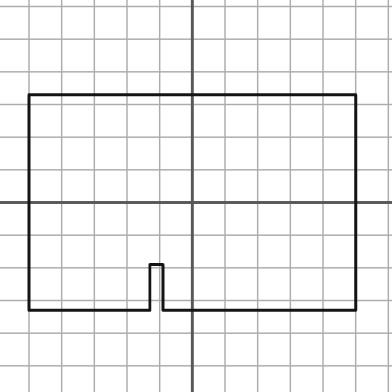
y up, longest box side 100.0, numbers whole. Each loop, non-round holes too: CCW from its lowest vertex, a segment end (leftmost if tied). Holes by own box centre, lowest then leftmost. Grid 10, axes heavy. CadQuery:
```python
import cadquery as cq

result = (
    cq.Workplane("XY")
    .moveTo(-50.0, -33.0)
    .lineTo(-13.0, -33.0)
    .lineTo(-13.0, -19.0)
    .lineTo(-9.0, -19.0)
    .lineTo(-9.0, -33.0)
    .lineTo(50.0, -33.0)
    .lineTo(50.0, 33.0)
    .lineTo(-50.0, 33.0)
    .close()
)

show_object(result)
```